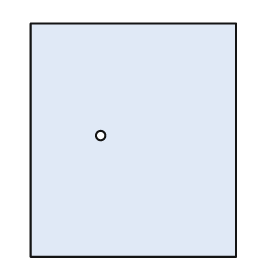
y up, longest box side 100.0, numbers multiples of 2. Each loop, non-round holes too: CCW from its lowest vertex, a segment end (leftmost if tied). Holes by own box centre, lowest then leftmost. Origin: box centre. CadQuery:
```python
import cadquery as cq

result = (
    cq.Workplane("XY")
    .moveTo(-44.0, -50.0)
    .lineTo(44.0, -50.0)
    .lineTo(44.0, 50.0)
    .lineTo(-44.0, 50.0)
    .close()
    .moveTo(-14.0, 2.0)
    .circle(2.0)
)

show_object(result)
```